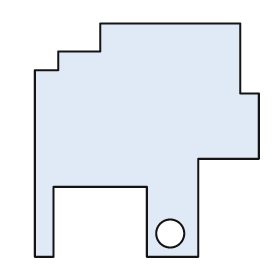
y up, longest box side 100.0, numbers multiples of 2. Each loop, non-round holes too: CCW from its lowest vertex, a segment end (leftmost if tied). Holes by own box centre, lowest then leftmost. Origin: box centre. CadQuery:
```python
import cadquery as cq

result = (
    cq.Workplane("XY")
    .moveTo(-48.0, -50.0)
    .lineTo(-40.0, -50.0)
    .lineTo(-40.0, -20.0)
    .lineTo(0.0, -20.0)
    .lineTo(0.0, -50.0)
    .lineTo(22.0, -50.0)
    .lineTo(22.0, -8.0)
    .lineTo(48.0, -8.0)
    .lineTo(48.0, 20.0)
    .lineTo(40.0, 20.0)
    .lineTo(40.0, 50.0)
    .lineTo(-20.0, 50.0)
    .lineTo(-20.0, 38.0)
    .lineTo(-38.0, 38.0)
    .lineTo(-38.0, 30.0)
    .lineTo(-48.0, 30.0)
    .close()
    .moveTo(10.0, -40.0)
    .circle(6.0)
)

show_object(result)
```